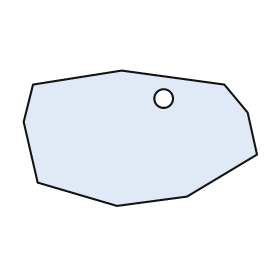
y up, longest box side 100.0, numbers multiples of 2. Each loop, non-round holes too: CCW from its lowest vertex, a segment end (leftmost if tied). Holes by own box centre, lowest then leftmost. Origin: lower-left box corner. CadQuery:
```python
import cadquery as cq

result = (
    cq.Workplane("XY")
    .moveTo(40.0, 0.0)
    .lineTo(70.0, 4.0)
    .lineTo(100.0, 22.0)
    .lineTo(96.0, 40.0)
    .lineTo(86.0, 52.0)
    .lineTo(42.0, 58.0)
    .lineTo(4.0, 52.0)
    .lineTo(0.0, 36.0)
    .lineTo(6.0, 10.0)
    .close()
    .moveTo(60.0, 46.0)
    .circle(4.0)
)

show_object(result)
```